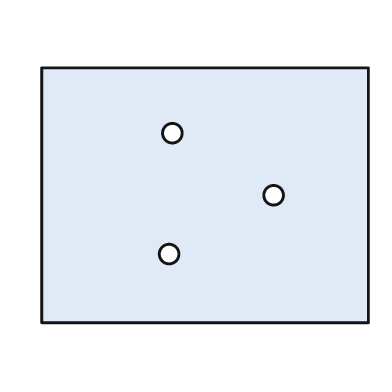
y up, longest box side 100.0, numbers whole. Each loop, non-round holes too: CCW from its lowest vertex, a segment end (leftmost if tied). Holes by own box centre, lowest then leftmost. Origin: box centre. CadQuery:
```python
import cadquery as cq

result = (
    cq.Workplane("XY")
    .moveTo(-50.0, -39.0)
    .lineTo(50.0, -39.0)
    .lineTo(50.0, 39.0)
    .lineTo(-50.0, 39.0)
    .close()
    .moveTo(-11.0, -18.0)
    .circle(3.0)
    .moveTo(21.0, 0.0)
    .circle(3.0)
    .moveTo(-10.0, 19.0)
    .circle(3.0)
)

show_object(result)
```